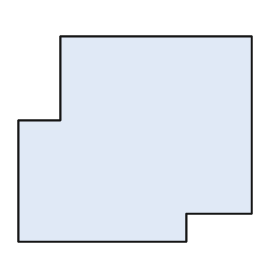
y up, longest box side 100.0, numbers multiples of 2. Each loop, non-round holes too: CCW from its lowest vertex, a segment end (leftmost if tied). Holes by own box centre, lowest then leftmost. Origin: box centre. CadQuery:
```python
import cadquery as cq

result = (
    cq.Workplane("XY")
    .moveTo(-50.0, -44.0)
    .lineTo(22.0, -44.0)
    .lineTo(22.0, -32.0)
    .lineTo(50.0, -32.0)
    .lineTo(50.0, 44.0)
    .lineTo(-32.0, 44.0)
    .lineTo(-32.0, 8.0)
    .lineTo(-50.0, 8.0)
    .close()
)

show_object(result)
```